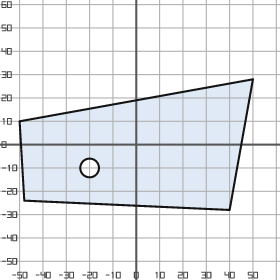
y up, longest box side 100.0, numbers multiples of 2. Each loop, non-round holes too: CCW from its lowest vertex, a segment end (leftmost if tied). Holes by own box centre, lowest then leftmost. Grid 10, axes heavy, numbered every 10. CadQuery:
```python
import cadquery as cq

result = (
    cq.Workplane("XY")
    .moveTo(40.0, -28.0)
    .lineTo(50.0, 28.0)
    .lineTo(-50.0, 10.0)
    .lineTo(-48.0, -24.0)
    .close()
    .moveTo(-20.0, -10.0)
    .circle(4.0)
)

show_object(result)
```